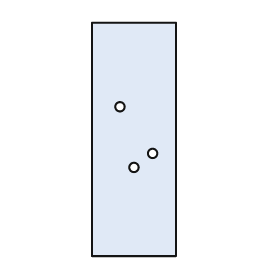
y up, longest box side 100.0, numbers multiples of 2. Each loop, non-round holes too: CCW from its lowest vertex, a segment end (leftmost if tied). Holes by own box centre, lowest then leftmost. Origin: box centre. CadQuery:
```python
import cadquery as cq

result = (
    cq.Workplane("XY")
    .moveTo(-18.0, -50.0)
    .lineTo(18.0, -50.0)
    .lineTo(18.0, 50.0)
    .lineTo(-18.0, 50.0)
    .close()
    .moveTo(0.0, -12.0)
    .circle(2.0)
    .moveTo(8.0, -6.0)
    .circle(2.0)
    .moveTo(-6.0, 14.0)
    .circle(2.0)
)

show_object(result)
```